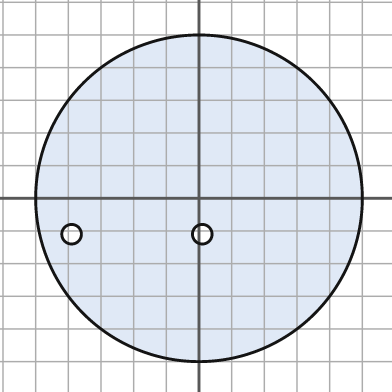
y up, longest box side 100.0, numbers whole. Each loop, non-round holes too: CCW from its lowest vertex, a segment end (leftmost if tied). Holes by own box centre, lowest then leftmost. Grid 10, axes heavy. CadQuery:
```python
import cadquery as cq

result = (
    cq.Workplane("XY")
    .moveTo(0.0, 0.0)
    .circle(50.0)
    .moveTo(-39.0, -11.0)
    .circle(3.0)
    .moveTo(1.0, -11.0)
    .circle(3.0)
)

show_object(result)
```